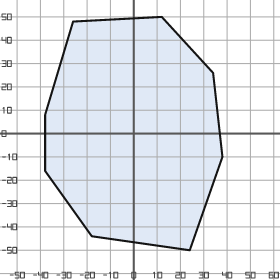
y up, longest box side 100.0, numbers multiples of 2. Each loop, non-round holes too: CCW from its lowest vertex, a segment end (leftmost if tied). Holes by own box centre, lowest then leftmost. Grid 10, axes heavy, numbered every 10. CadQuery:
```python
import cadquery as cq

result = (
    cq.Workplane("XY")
    .moveTo(24.0, -50.0)
    .lineTo(38.0, -10.0)
    .lineTo(34.0, 26.0)
    .lineTo(12.0, 50.0)
    .lineTo(-26.0, 48.0)
    .lineTo(-38.0, 8.0)
    .lineTo(-38.0, -16.0)
    .lineTo(-18.0, -44.0)
    .close()
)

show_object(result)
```